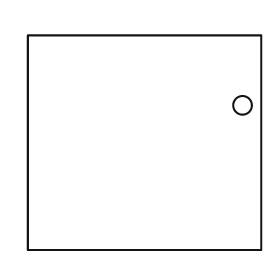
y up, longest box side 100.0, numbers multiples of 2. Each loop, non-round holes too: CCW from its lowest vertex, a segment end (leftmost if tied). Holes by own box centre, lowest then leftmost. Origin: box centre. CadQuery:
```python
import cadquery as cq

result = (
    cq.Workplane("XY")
    .moveTo(-50.0, -46.0)
    .lineTo(50.0, -46.0)
    .lineTo(50.0, 46.0)
    .lineTo(-50.0, 46.0)
    .close()
    .moveTo(42.0, 16.0)
    .circle(4.0)
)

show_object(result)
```